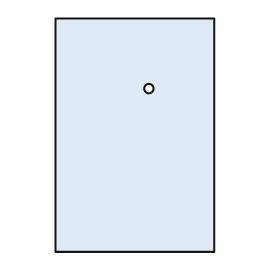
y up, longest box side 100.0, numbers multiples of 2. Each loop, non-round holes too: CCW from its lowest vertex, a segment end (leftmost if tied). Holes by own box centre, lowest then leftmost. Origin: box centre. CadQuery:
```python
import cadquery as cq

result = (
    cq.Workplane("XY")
    .moveTo(-34.0, -50.0)
    .lineTo(34.0, -50.0)
    .lineTo(34.0, 50.0)
    .lineTo(-34.0, 50.0)
    .close()
    .moveTo(6.0, 20.0)
    .circle(2.0)
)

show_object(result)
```